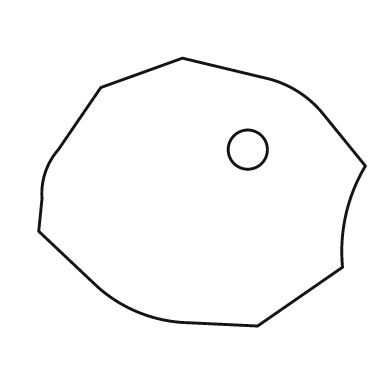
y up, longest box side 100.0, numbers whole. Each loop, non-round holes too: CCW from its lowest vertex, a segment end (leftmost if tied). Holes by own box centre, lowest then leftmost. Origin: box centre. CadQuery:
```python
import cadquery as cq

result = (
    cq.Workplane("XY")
    .moveTo(17.0, -41.0)
    .lineTo(43.0, -23.0)
    .threePointArc((44.0, -7.0), (50.0, 8.0))
    .lineTo(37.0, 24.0)
    .threePointArc((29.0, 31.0), (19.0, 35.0))
    .lineTo(-6.0, 41.0)
    .lineTo(-31.0, 32.0)
    .lineTo(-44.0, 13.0)
    .threePointArc((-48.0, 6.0), (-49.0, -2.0))
    .lineTo(-50.0, -12.0)
    .lineTo(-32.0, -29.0)
    .threePointArc((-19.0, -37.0), (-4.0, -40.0))
    .close()
    .moveTo(14.0, 13.0)
    .circle(6.0)
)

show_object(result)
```